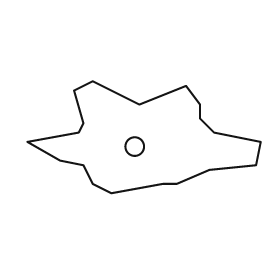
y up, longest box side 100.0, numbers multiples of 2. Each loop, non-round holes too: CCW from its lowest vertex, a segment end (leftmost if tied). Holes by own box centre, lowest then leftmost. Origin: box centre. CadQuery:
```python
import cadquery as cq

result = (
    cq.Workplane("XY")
    .moveTo(-14.0, -24.0)
    .lineTo(8.0, -20.0)
    .lineTo(14.0, -20.0)
    .lineTo(28.0, -14.0)
    .lineTo(48.0, -12.0)
    .lineTo(50.0, -2.0)
    .lineTo(30.0, 2.0)
    .lineTo(24.0, 8.0)
    .lineTo(24.0, 14.0)
    .lineTo(18.0, 22.0)
    .lineTo(-2.0, 14.0)
    .lineTo(-22.0, 24.0)
    .lineTo(-30.0, 20.0)
    .lineTo(-26.0, 6.0)
    .lineTo(-28.0, 2.0)
    .lineTo(-50.0, -2.0)
    .lineTo(-36.0, -10.0)
    .lineTo(-26.0, -12.0)
    .lineTo(-22.0, -20.0)
    .close()
    .moveTo(-4.0, -4.0)
    .circle(4.0)
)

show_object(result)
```